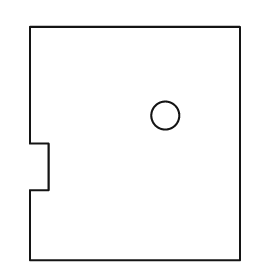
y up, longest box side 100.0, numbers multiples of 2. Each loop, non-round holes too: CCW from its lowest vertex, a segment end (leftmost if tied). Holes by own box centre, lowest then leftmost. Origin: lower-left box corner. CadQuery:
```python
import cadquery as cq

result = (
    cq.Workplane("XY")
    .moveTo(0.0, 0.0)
    .lineTo(90.0, 0.0)
    .lineTo(90.0, 100.0)
    .lineTo(0.0, 100.0)
    .lineTo(0.0, 50.0)
    .lineTo(8.0, 50.0)
    .lineTo(8.0, 30.0)
    .lineTo(0.0, 30.0)
    .close()
    .moveTo(58.0, 62.0)
    .circle(6.0)
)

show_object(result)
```